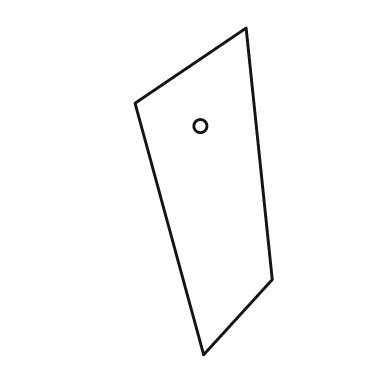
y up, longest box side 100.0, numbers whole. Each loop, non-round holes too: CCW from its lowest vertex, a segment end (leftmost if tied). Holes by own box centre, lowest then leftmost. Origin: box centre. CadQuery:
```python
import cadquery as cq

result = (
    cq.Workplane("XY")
    .moveTo(0.0, -50.0)
    .lineTo(21.0, -27.0)
    .lineTo(13.0, 50.0)
    .lineTo(-21.0, 27.0)
    .close()
    .moveTo(-1.0, 20.0)
    .circle(2.0)
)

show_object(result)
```